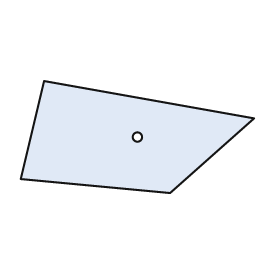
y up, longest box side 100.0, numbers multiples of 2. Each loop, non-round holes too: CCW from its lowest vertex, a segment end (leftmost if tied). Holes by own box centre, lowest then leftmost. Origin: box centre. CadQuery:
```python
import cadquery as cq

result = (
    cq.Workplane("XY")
    .moveTo(14.0, -24.0)
    .lineTo(50.0, 8.0)
    .lineTo(-40.0, 24.0)
    .lineTo(-50.0, -18.0)
    .close()
    .moveTo(0.0, 0.0)
    .circle(2.0)
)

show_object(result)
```